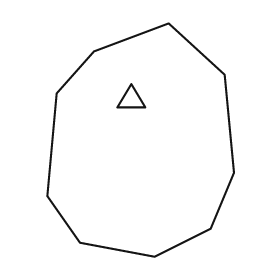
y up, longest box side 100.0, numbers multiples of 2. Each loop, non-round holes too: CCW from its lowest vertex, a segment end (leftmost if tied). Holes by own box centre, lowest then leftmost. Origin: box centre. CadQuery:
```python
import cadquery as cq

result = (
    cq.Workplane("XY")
    .moveTo(6.0, -50.0)
    .lineTo(30.0, -38.0)
    .lineTo(40.0, -14.0)
    .lineTo(36.0, 28.0)
    .lineTo(12.0, 50.0)
    .lineTo(-20.0, 38.0)
    .lineTo(-36.0, 20.0)
    .lineTo(-40.0, -24.0)
    .lineTo(-26.0, -44.0)
    .close()
    .moveTo(-10.0, 14.0)
    .lineTo(2.0, 14.0)
    .lineTo(-4.0, 24.0)
    .close()
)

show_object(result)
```